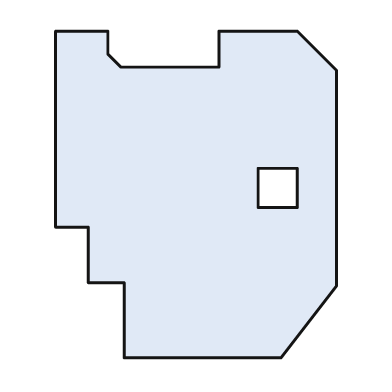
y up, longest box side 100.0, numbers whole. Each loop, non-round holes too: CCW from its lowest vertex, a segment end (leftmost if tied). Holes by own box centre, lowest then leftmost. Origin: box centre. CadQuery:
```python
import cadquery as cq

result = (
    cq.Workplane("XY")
    .moveTo(-22.0, -50.0)
    .lineTo(26.0, -50.0)
    .lineTo(43.0, -28.0)
    .lineTo(43.0, 38.0)
    .lineTo(31.0, 50.0)
    .lineTo(7.0, 50.0)
    .lineTo(7.0, 39.0)
    .lineTo(-23.0, 39.0)
    .lineTo(-27.0, 43.0)
    .lineTo(-27.0, 50.0)
    .lineTo(-43.0, 50.0)
    .lineTo(-43.0, -10.0)
    .lineTo(-33.0, -10.0)
    .lineTo(-33.0, -27.0)
    .lineTo(-22.0, -27.0)
    .close()
    .moveTo(19.0, -4.0)
    .lineTo(31.0, -4.0)
    .lineTo(31.0, 8.0)
    .lineTo(19.0, 8.0)
    .close()
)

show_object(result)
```